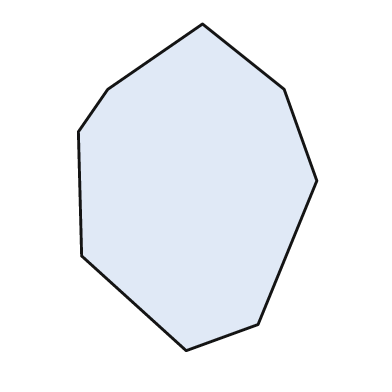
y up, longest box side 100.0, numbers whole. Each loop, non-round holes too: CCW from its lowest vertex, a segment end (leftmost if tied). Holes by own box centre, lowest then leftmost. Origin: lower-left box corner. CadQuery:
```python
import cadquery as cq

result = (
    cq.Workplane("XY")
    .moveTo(33.0, 0.0)
    .lineTo(55.0, 8.0)
    .lineTo(73.0, 52.0)
    .lineTo(63.0, 80.0)
    .lineTo(38.0, 100.0)
    .lineTo(9.0, 80.0)
    .lineTo(0.0, 67.0)
    .lineTo(1.0, 29.0)
    .close()
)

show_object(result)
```